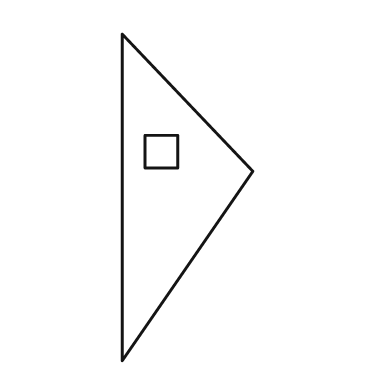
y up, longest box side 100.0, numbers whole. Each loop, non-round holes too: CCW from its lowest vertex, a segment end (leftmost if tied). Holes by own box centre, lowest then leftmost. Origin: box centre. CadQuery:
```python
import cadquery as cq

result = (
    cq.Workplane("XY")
    .moveTo(-20.0, -50.0)
    .lineTo(20.0, 8.0)
    .lineTo(-20.0, 50.0)
    .close()
    .moveTo(-13.0, 9.0)
    .lineTo(-3.0, 9.0)
    .lineTo(-3.0, 19.0)
    .lineTo(-13.0, 19.0)
    .close()
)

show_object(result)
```